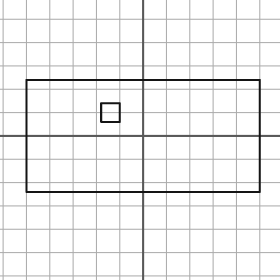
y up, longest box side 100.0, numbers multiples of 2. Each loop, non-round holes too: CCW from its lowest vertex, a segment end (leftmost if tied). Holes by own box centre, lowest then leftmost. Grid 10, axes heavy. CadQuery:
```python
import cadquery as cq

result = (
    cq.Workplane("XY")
    .moveTo(-50.0, -24.0)
    .lineTo(50.0, -24.0)
    .lineTo(50.0, 24.0)
    .lineTo(-50.0, 24.0)
    .close()
    .moveTo(-18.0, 6.0)
    .lineTo(-10.0, 6.0)
    .lineTo(-10.0, 14.0)
    .lineTo(-18.0, 14.0)
    .close()
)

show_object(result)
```